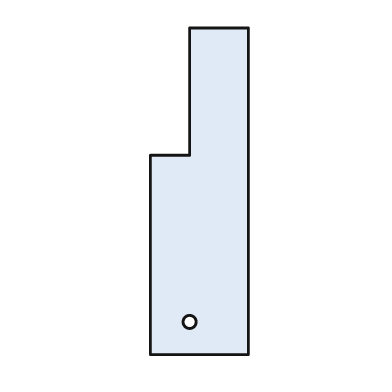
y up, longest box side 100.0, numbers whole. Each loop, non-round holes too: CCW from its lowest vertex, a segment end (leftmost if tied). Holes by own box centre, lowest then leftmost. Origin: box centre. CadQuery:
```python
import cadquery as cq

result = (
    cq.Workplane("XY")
    .moveTo(-15.0, -50.0)
    .lineTo(15.0, -50.0)
    .lineTo(15.0, 50.0)
    .lineTo(-3.0, 50.0)
    .lineTo(-3.0, 11.0)
    .lineTo(-15.0, 11.0)
    .close()
    .moveTo(-3.0, -40.0)
    .circle(2.0)
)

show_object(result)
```